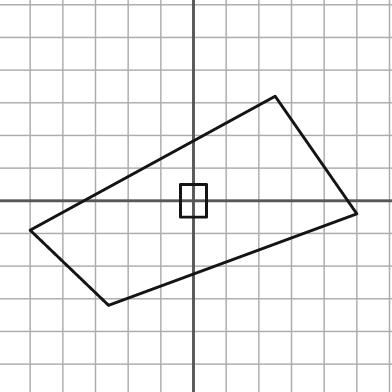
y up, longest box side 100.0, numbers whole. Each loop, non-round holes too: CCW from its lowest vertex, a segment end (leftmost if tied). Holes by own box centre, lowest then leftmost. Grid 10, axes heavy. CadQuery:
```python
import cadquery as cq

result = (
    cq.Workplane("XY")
    .moveTo(-26.0, -32.0)
    .lineTo(50.0, -4.0)
    .lineTo(25.0, 32.0)
    .lineTo(-50.0, -9.0)
    .close()
    .moveTo(-4.0, -5.0)
    .lineTo(4.0, -5.0)
    .lineTo(4.0, 5.0)
    .lineTo(-4.0, 5.0)
    .close()
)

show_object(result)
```